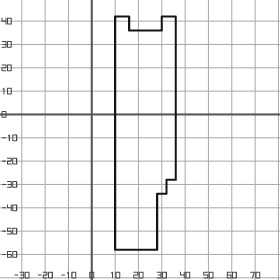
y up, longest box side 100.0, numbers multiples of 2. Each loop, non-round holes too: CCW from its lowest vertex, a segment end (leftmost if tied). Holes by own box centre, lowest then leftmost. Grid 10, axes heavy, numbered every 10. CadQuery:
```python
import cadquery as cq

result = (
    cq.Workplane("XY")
    .moveTo(10.0, -58.0)
    .lineTo(28.0, -58.0)
    .lineTo(28.0, -34.0)
    .lineTo(32.0, -34.0)
    .lineTo(32.0, -28.0)
    .lineTo(36.0, -28.0)
    .lineTo(36.0, 42.0)
    .lineTo(30.0, 42.0)
    .lineTo(30.0, 36.0)
    .lineTo(16.0, 36.0)
    .lineTo(16.0, 42.0)
    .lineTo(10.0, 42.0)
    .close()
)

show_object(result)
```